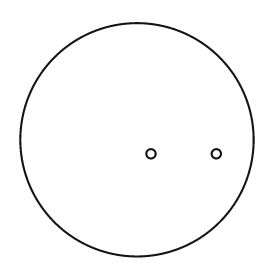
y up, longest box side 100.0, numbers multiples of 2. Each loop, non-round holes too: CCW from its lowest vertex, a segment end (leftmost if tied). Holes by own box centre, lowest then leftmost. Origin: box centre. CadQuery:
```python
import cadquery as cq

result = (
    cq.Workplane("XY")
    .moveTo(0.0, 0.0)
    .circle(50.0)
    .moveTo(6.0, -6.0)
    .circle(2.0)
    .moveTo(34.0, -6.0)
    .circle(2.0)
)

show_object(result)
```